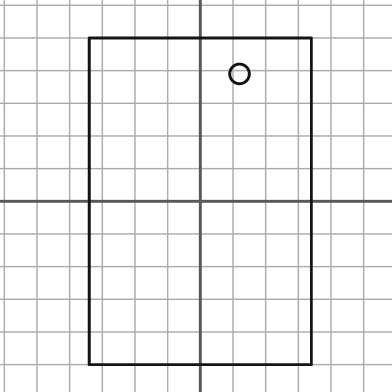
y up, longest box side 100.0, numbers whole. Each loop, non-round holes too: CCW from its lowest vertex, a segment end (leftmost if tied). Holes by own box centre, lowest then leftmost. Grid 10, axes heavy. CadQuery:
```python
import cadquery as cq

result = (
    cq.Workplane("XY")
    .moveTo(-34.0, -50.0)
    .lineTo(34.0, -50.0)
    .lineTo(34.0, 50.0)
    .lineTo(-34.0, 50.0)
    .close()
    .moveTo(12.0, 39.0)
    .circle(3.0)
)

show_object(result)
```